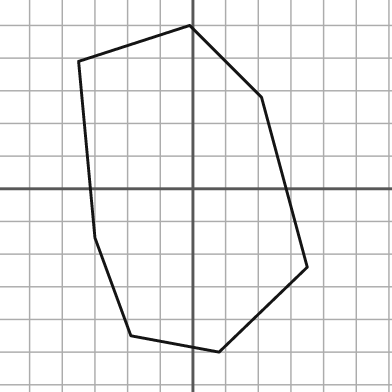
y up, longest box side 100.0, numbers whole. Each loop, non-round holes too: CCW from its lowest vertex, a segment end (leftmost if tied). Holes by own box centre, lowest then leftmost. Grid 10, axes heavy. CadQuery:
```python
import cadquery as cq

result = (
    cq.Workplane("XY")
    .moveTo(8.0, -50.0)
    .lineTo(35.0, -24.0)
    .lineTo(21.0, 28.0)
    .lineTo(-1.0, 50.0)
    .lineTo(-35.0, 39.0)
    .lineTo(-30.0, -15.0)
    .lineTo(-19.0, -45.0)
    .close()
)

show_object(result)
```